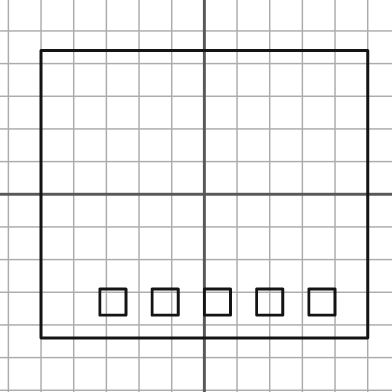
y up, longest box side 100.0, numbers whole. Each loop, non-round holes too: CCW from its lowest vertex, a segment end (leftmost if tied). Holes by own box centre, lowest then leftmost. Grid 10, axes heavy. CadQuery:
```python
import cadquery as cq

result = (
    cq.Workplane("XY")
    .moveTo(-50.0, -44.0)
    .lineTo(50.0, -44.0)
    .lineTo(50.0, 44.0)
    .lineTo(-50.0, 44.0)
    .close()
    .moveTo(-32.0, -37.0)
    .lineTo(-24.0, -37.0)
    .lineTo(-24.0, -29.0)
    .lineTo(-32.0, -29.0)
    .close()
    .moveTo(-16.0, -37.0)
    .lineTo(-8.0, -37.0)
    .lineTo(-8.0, -29.0)
    .lineTo(-16.0, -29.0)
    .close()
    .moveTo(0.0, -37.0)
    .lineTo(8.0, -37.0)
    .lineTo(8.0, -29.0)
    .lineTo(0.0, -29.0)
    .close()
    .moveTo(16.0, -37.0)
    .lineTo(24.0, -37.0)
    .lineTo(24.0, -29.0)
    .lineTo(16.0, -29.0)
    .close()
    .moveTo(32.0, -37.0)
    .lineTo(40.0, -37.0)
    .lineTo(40.0, -29.0)
    .lineTo(32.0, -29.0)
    .close()
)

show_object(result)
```